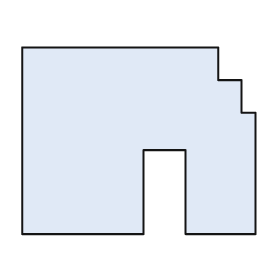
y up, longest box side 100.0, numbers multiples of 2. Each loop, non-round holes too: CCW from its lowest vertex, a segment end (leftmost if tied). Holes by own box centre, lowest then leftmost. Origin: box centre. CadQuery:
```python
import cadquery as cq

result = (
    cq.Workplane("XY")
    .moveTo(-50.0, -40.0)
    .lineTo(2.0, -40.0)
    .lineTo(2.0, -4.0)
    .lineTo(20.0, -4.0)
    .lineTo(20.0, -40.0)
    .lineTo(50.0, -40.0)
    .lineTo(50.0, 12.0)
    .lineTo(44.0, 12.0)
    .lineTo(44.0, 26.0)
    .lineTo(34.0, 26.0)
    .lineTo(34.0, 40.0)
    .lineTo(-50.0, 40.0)
    .close()
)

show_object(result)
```